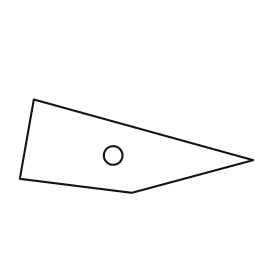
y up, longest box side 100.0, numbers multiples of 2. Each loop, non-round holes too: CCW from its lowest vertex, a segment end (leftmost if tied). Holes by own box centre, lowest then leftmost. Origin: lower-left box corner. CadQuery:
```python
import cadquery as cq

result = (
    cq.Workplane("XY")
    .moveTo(48.0, 0.0)
    .lineTo(100.0, 14.0)
    .lineTo(6.0, 40.0)
    .lineTo(0.0, 6.0)
    .close()
    .moveTo(40.0, 16.0)
    .circle(4.0)
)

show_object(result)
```